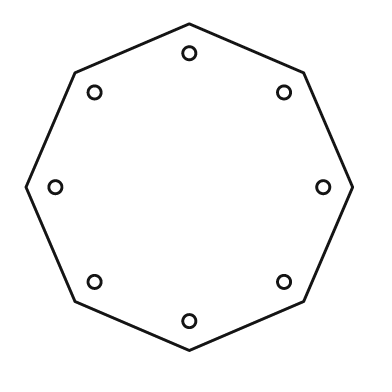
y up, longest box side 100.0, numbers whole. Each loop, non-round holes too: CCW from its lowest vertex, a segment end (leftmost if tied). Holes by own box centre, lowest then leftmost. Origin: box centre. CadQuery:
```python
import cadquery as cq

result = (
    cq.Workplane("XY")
    .moveTo(0.0, -50.0)
    .lineTo(35.0, -35.0)
    .lineTo(50.0, 0.0)
    .lineTo(35.0, 35.0)
    .lineTo(0.0, 50.0)
    .lineTo(-35.0, 35.0)
    .lineTo(-50.0, 0.0)
    .lineTo(-35.0, -35.0)
    .close()
    .moveTo(0.0, -41.0)
    .circle(2.0)
    .moveTo(-29.0, -29.0)
    .circle(2.0)
    .moveTo(29.0, -29.0)
    .circle(2.0)
    .moveTo(-41.0, 0.0)
    .circle(2.0)
    .moveTo(41.0, 0.0)
    .circle(2.0)
    .moveTo(-29.0, 29.0)
    .circle(2.0)
    .moveTo(29.0, 29.0)
    .circle(2.0)
    .moveTo(0.0, 41.0)
    .circle(2.0)
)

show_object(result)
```